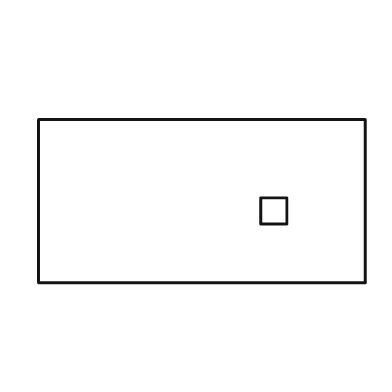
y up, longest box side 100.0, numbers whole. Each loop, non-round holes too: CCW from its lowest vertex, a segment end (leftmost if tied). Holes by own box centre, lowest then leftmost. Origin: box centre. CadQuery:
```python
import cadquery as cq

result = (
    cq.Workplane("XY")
    .moveTo(-50.0, -25.0)
    .lineTo(50.0, -25.0)
    .lineTo(50.0, 25.0)
    .lineTo(-50.0, 25.0)
    .close()
    .moveTo(18.0, -7.0)
    .lineTo(26.0, -7.0)
    .lineTo(26.0, 1.0)
    .lineTo(18.0, 1.0)
    .close()
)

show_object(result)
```